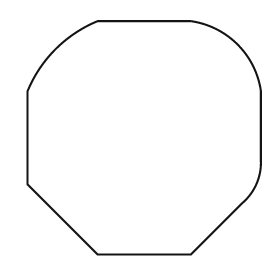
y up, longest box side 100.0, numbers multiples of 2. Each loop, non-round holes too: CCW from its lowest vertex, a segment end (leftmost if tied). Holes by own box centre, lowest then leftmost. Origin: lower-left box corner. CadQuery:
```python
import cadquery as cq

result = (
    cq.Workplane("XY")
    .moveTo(30.0, 0.0)
    .lineTo(70.0, 0.0)
    .lineTo(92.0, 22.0)
    .threePointArc((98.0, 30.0), (100.0, 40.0))
    .lineTo(100.0, 70.0)
    .threePointArc((90.0, 90.0), (70.0, 100.0))
    .lineTo(30.0, 100.0)
    .threePointArc((12.0, 88.0), (0.0, 70.0))
    .lineTo(0.0, 30.0)
    .close()
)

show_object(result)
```